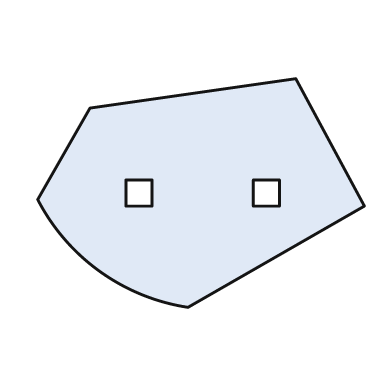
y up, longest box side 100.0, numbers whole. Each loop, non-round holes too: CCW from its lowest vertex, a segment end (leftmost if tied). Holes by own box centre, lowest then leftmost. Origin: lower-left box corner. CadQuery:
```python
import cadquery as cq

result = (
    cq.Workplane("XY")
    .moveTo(46.0, 0.0)
    .lineTo(100.0, 31.0)
    .lineTo(79.0, 70.0)
    .lineTo(16.0, 61.0)
    .lineTo(0.0, 33.0)
    .threePointArc((19.0, 11.0), (46.0, 0.0))
    .close()
    .moveTo(27.0, 31.0)
    .lineTo(35.0, 31.0)
    .lineTo(35.0, 39.0)
    .lineTo(27.0, 39.0)
    .close()
    .moveTo(66.0, 31.0)
    .lineTo(74.0, 31.0)
    .lineTo(74.0, 39.0)
    .lineTo(66.0, 39.0)
    .close()
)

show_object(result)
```